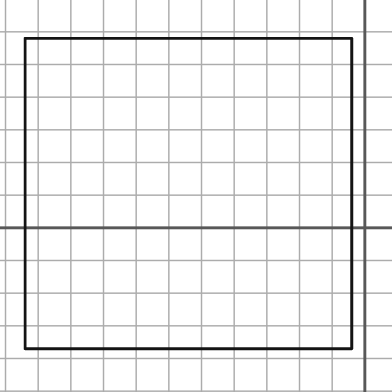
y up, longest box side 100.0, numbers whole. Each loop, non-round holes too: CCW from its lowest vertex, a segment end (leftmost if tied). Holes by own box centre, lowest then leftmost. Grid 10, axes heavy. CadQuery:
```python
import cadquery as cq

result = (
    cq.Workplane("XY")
    .moveTo(-104.0, -37.0)
    .lineTo(-4.0, -37.0)
    .lineTo(-4.0, 58.0)
    .lineTo(-104.0, 58.0)
    .close()
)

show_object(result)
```